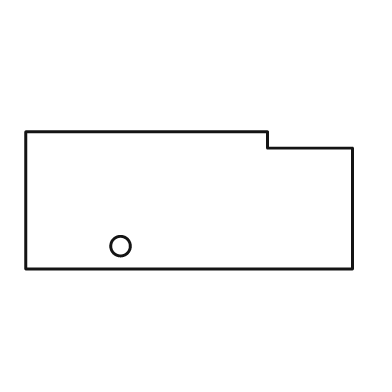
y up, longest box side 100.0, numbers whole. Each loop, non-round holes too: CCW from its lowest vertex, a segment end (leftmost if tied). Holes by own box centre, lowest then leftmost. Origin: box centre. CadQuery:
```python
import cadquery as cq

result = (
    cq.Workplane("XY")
    .moveTo(-50.0, -21.0)
    .lineTo(50.0, -21.0)
    .lineTo(50.0, 16.0)
    .lineTo(24.0, 16.0)
    .lineTo(24.0, 21.0)
    .lineTo(-50.0, 21.0)
    .close()
    .moveTo(-21.0, -14.0)
    .circle(3.0)
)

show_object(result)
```